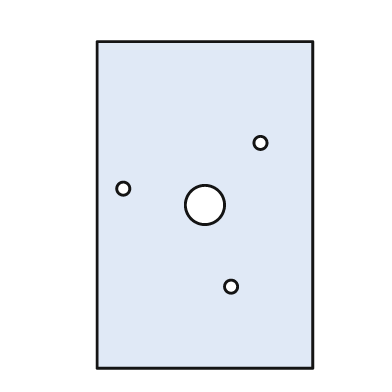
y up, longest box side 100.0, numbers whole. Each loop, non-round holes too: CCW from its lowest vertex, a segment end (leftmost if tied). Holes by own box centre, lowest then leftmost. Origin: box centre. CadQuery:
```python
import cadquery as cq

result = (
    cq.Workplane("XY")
    .moveTo(-33.0, -50.0)
    .lineTo(33.0, -50.0)
    .lineTo(33.0, 50.0)
    .lineTo(-33.0, 50.0)
    .close()
    .moveTo(8.0, -25.0)
    .circle(2.0)
    .moveTo(0.0, 0.0)
    .circle(6.0)
    .moveTo(-25.0, 5.0)
    .circle(2.0)
    .moveTo(17.0, 19.0)
    .circle(2.0)
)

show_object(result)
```